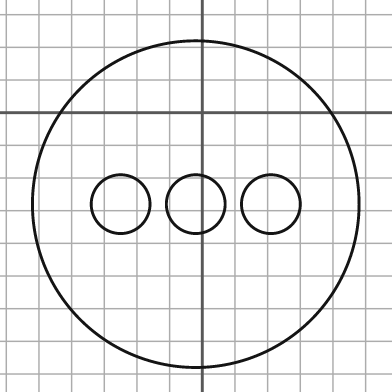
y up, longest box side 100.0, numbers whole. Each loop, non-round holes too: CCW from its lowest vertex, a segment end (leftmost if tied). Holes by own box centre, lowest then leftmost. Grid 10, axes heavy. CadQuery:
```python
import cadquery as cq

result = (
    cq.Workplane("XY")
    .moveTo(-2.0, -28.0)
    .circle(50.0)
    .moveTo(-25.0, -28.0)
    .circle(9.0)
    .moveTo(-2.0, -28.0)
    .circle(9.0)
    .moveTo(21.0, -28.0)
    .circle(9.0)
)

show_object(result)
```